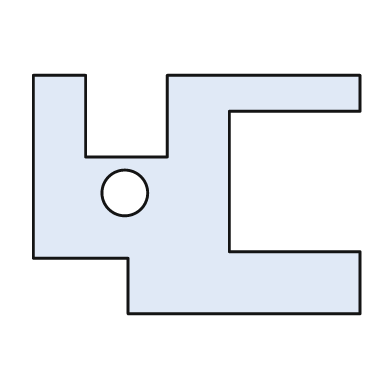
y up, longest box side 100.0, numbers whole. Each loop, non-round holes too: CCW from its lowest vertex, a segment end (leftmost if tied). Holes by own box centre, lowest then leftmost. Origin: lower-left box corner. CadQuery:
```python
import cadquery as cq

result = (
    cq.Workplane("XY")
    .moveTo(29.0, 0.0)
    .lineTo(100.0, 0.0)
    .lineTo(100.0, 19.0)
    .lineTo(60.0, 19.0)
    .lineTo(60.0, 62.0)
    .lineTo(100.0, 62.0)
    .lineTo(100.0, 73.0)
    .lineTo(41.0, 73.0)
    .lineTo(41.0, 48.0)
    .lineTo(16.0, 48.0)
    .lineTo(16.0, 73.0)
    .lineTo(0.0, 73.0)
    .lineTo(0.0, 17.0)
    .lineTo(29.0, 17.0)
    .close()
    .moveTo(28.0, 37.0)
    .circle(7.0)
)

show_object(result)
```